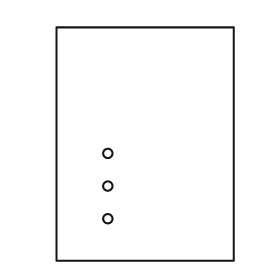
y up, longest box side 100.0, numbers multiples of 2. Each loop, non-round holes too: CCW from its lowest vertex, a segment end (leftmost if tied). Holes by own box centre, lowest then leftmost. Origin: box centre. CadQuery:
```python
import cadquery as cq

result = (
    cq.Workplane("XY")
    .moveTo(-38.0, -50.0)
    .lineTo(38.0, -50.0)
    .lineTo(38.0, 50.0)
    .lineTo(-38.0, 50.0)
    .close()
    .moveTo(-16.0, -32.0)
    .circle(2.0)
    .moveTo(-16.0, -18.0)
    .circle(2.0)
    .moveTo(-16.0, -4.0)
    .circle(2.0)
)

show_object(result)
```